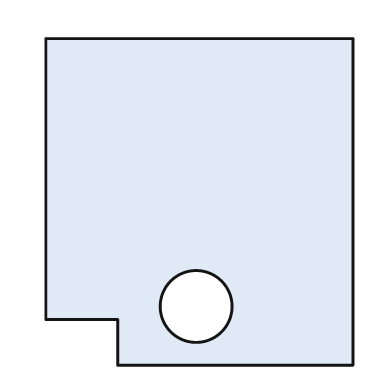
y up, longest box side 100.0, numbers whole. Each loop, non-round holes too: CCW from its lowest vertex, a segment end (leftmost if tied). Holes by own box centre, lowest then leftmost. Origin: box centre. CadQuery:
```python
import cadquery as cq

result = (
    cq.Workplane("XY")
    .moveTo(-25.0, -50.0)
    .lineTo(47.0, -50.0)
    .lineTo(47.0, 50.0)
    .lineTo(-47.0, 50.0)
    .lineTo(-47.0, -36.0)
    .lineTo(-25.0, -36.0)
    .close()
    .moveTo(-1.0, -32.0)
    .circle(11.0)
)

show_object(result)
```